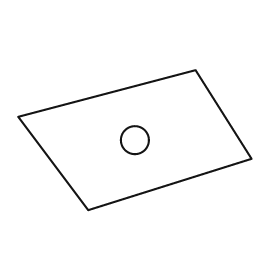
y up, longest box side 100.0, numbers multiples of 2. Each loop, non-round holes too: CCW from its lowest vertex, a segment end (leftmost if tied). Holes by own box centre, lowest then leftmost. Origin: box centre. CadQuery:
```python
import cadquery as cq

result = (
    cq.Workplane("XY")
    .moveTo(-20.0, -30.0)
    .lineTo(50.0, -8.0)
    .lineTo(26.0, 30.0)
    .lineTo(-50.0, 10.0)
    .close()
    .moveTo(0.0, 0.0)
    .circle(6.0)
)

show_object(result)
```